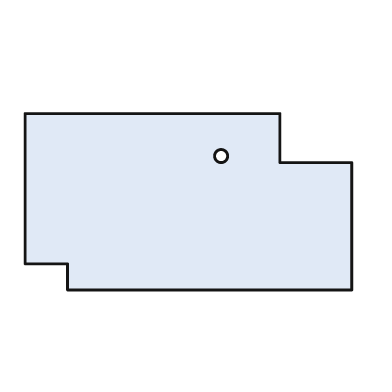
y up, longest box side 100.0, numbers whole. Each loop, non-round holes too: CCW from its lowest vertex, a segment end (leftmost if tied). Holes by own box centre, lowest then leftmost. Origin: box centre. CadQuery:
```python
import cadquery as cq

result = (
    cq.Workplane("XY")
    .moveTo(-37.0, -27.0)
    .lineTo(50.0, -27.0)
    .lineTo(50.0, 12.0)
    .lineTo(28.0, 12.0)
    .lineTo(28.0, 27.0)
    .lineTo(-50.0, 27.0)
    .lineTo(-50.0, -19.0)
    .lineTo(-37.0, -19.0)
    .close()
    .moveTo(10.0, 14.0)
    .circle(2.0)
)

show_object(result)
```